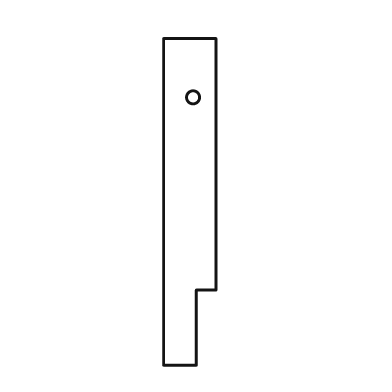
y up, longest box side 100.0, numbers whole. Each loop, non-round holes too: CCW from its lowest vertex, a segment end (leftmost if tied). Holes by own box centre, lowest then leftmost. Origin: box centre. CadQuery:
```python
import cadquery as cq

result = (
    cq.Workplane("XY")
    .moveTo(-8.0, -50.0)
    .lineTo(2.0, -50.0)
    .lineTo(2.0, -27.0)
    .lineTo(8.0, -27.0)
    .lineTo(8.0, 50.0)
    .lineTo(-8.0, 50.0)
    .close()
    .moveTo(1.0, 32.0)
    .circle(2.0)
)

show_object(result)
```